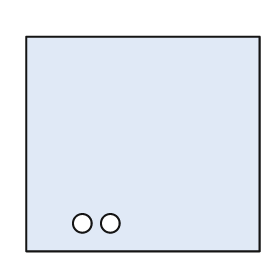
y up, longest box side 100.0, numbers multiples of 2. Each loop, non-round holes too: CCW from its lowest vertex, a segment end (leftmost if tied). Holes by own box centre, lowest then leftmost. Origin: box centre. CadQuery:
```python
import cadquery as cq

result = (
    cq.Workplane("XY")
    .moveTo(-50.0, -46.0)
    .lineTo(50.0, -46.0)
    .lineTo(50.0, 46.0)
    .lineTo(-50.0, 46.0)
    .close()
    .moveTo(-26.0, -34.0)
    .circle(4.0)
    .moveTo(-14.0, -34.0)
    .circle(4.0)
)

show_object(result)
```